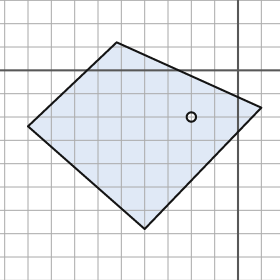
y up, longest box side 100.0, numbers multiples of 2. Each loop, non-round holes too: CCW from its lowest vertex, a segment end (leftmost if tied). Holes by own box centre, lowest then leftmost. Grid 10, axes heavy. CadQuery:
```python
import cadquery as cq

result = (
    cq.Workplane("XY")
    .moveTo(-40.0, -68.0)
    .lineTo(10.0, -16.0)
    .lineTo(-52.0, 12.0)
    .lineTo(-90.0, -24.0)
    .close()
    .moveTo(-20.0, -20.0)
    .circle(2.0)
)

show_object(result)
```